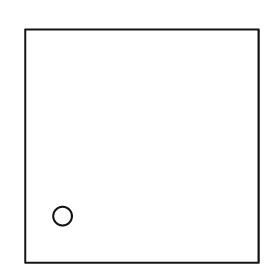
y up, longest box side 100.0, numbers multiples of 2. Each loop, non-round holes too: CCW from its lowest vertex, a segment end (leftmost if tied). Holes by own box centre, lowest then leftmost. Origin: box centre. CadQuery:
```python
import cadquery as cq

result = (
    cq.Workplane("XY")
    .moveTo(-50.0, -50.0)
    .lineTo(50.0, -50.0)
    .lineTo(50.0, 50.0)
    .lineTo(-50.0, 50.0)
    .close()
    .moveTo(-34.0, -30.0)
    .circle(4.0)
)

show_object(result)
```